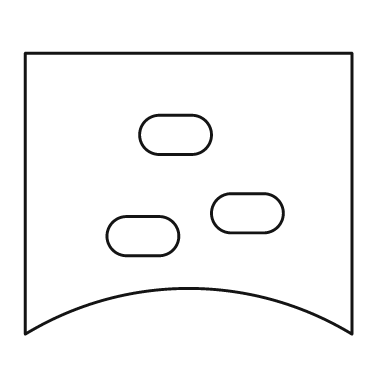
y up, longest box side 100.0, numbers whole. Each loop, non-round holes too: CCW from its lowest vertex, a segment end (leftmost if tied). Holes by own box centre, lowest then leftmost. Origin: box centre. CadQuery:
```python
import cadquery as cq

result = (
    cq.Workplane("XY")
    .moveTo(-50.0, -43.0)
    .threePointArc((0.0, -29.0), (50.0, -43.0))
    .lineTo(50.0, 43.0)
    .lineTo(-50.0, 43.0)
    .close()
    .moveTo(-19.0, -19.0)
    .lineTo(-9.0, -19.0)
    .threePointArc((-3.0, -13.0), (-9.0, -7.0))
    .lineTo(-19.0, -7.0)
    .threePointArc((-25.0, -13.0), (-19.0, -19.0))
    .close()
    .moveTo(13.0, -12.0)
    .lineTo(23.0, -12.0)
    .threePointArc((29.0, -6.0), (23.0, 0.0))
    .lineTo(13.0, 0.0)
    .threePointArc((7.0, -6.0), (13.0, -12.0))
    .close()
    .moveTo(-9.0, 12.0)
    .lineTo(1.0, 12.0)
    .threePointArc((7.0, 18.0), (1.0, 24.0))
    .lineTo(-9.0, 24.0)
    .threePointArc((-15.0, 18.0), (-9.0, 12.0))
    .close()
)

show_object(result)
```